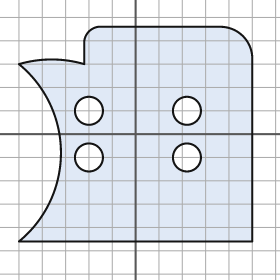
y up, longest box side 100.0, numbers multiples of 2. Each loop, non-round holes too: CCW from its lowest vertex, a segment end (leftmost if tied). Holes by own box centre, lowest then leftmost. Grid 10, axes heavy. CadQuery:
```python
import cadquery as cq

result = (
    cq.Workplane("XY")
    .moveTo(-50.0, -46.0)
    .lineTo(50.0, -46.0)
    .lineTo(50.0, 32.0)
    .threePointArc((46.0, 42.0), (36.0, 46.0))
    .lineTo(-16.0, 46.0)
    .threePointArc((-20.0, 44.0), (-22.0, 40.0))
    .lineTo(-22.0, 30.0)
    .threePointArc((-36.0, 32.0), (-50.0, 30.0))
    .threePointArc((-32.0, -8.0), (-50.0, -46.0))
    .close()
    .moveTo(-20.0, -10.0)
    .circle(6.0)
    .moveTo(22.0, -10.0)
    .circle(6.0)
    .moveTo(-20.0, 10.0)
    .circle(6.0)
    .moveTo(22.0, 10.0)
    .circle(6.0)
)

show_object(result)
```